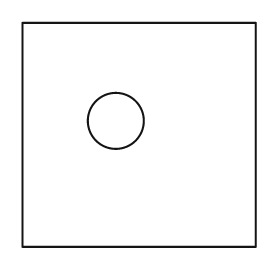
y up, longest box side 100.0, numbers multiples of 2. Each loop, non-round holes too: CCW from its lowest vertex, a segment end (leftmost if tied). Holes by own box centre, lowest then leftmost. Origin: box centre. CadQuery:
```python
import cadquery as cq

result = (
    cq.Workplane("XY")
    .moveTo(-50.0, -48.0)
    .lineTo(50.0, -48.0)
    .lineTo(50.0, 48.0)
    .lineTo(-50.0, 48.0)
    .close()
    .moveTo(-10.0, 6.0)
    .circle(12.0)
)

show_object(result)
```